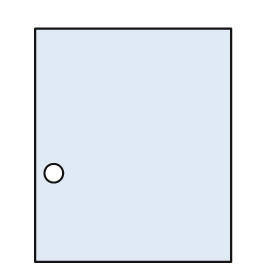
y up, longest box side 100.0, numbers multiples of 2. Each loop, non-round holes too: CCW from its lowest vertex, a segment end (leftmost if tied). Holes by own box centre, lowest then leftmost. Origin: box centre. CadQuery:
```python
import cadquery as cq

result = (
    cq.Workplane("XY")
    .moveTo(-42.0, -50.0)
    .lineTo(42.0, -50.0)
    .lineTo(42.0, 50.0)
    .lineTo(-42.0, 50.0)
    .close()
    .moveTo(-34.0, -12.0)
    .circle(4.0)
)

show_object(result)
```